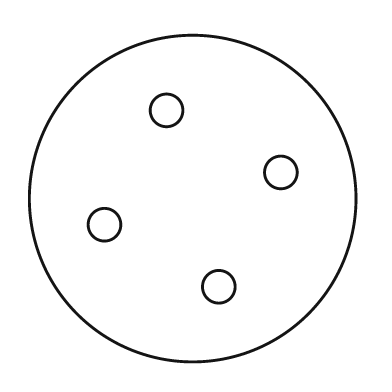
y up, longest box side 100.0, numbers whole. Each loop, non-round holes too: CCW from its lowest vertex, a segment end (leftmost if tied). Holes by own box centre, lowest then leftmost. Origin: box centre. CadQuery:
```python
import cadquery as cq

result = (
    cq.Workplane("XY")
    .moveTo(0.0, 0.0)
    .circle(50.0)
    .moveTo(8.0, -27.0)
    .circle(5.0)
    .moveTo(-27.0, -8.0)
    .circle(5.0)
    .moveTo(27.0, 8.0)
    .circle(5.0)
    .moveTo(-8.0, 27.0)
    .circle(5.0)
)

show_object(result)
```